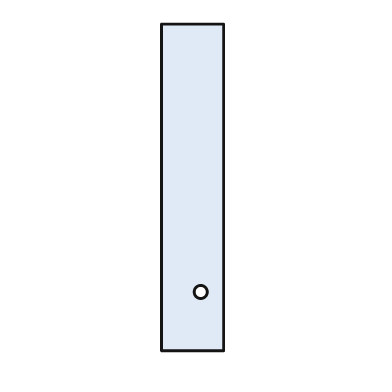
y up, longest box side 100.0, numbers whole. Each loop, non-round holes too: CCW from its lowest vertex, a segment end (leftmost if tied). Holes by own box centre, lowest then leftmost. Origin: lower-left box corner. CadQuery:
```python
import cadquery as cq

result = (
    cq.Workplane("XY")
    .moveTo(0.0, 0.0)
    .lineTo(19.0, 0.0)
    .lineTo(19.0, 100.0)
    .lineTo(0.0, 100.0)
    .close()
    .moveTo(12.0, 18.0)
    .circle(2.0)
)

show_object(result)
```